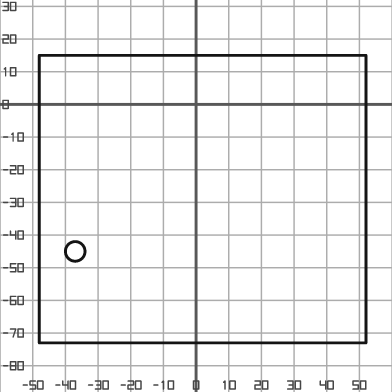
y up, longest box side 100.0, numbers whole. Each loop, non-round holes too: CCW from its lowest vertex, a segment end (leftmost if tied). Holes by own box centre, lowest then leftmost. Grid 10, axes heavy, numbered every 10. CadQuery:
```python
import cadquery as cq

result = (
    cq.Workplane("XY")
    .moveTo(-48.0, -73.0)
    .lineTo(52.0, -73.0)
    .lineTo(52.0, 15.0)
    .lineTo(-48.0, 15.0)
    .close()
    .moveTo(-37.0, -45.0)
    .circle(3.0)
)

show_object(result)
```